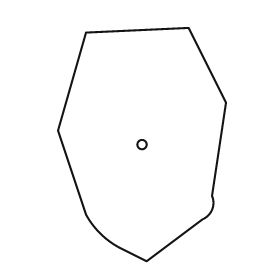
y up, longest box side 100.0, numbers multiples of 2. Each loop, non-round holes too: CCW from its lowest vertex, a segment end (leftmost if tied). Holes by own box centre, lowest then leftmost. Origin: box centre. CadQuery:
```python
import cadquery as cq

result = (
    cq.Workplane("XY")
    .moveTo(2.0, -50.0)
    .lineTo(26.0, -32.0)
    .threePointArc((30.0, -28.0), (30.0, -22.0))
    .lineTo(36.0, 18.0)
    .lineTo(20.0, 50.0)
    .lineTo(-24.0, 48.0)
    .lineTo(-36.0, 6.0)
    .lineTo(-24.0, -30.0)
    .threePointArc((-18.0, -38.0), (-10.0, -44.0))
    .close()
    .moveTo(0.0, 0.0)
    .circle(2.0)
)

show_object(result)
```